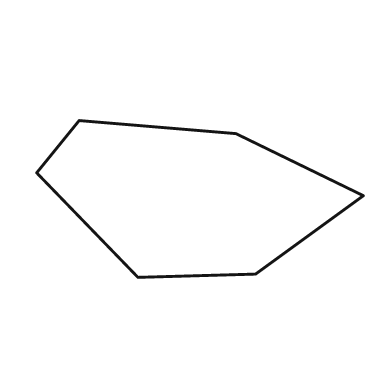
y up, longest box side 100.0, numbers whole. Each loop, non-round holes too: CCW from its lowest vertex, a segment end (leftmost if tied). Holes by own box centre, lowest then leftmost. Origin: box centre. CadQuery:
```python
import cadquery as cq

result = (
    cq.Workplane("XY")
    .moveTo(-19.0, -24.0)
    .lineTo(17.0, -23.0)
    .lineTo(50.0, 1.0)
    .lineTo(11.0, 20.0)
    .lineTo(-37.0, 24.0)
    .lineTo(-50.0, 8.0)
    .close()
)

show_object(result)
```